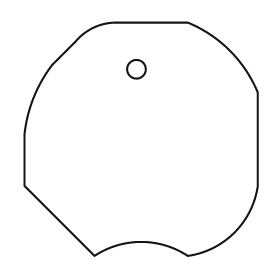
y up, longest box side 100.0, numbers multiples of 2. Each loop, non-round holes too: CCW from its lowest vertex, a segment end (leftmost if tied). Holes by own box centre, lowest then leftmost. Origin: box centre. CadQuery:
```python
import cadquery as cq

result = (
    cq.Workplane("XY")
    .moveTo(-20.0, -50.0)
    .threePointArc((0.0, -44.0), (20.0, -50.0))
    .threePointArc((40.0, -40.0), (50.0, -20.0))
    .lineTo(50.0, 20.0)
    .threePointArc((38.0, 38.0), (20.0, 50.0))
    .lineTo(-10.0, 50.0)
    .threePointArc((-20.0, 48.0), (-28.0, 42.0))
    .lineTo(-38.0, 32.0)
    .threePointArc((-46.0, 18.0), (-50.0, 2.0))
    .lineTo(-50.0, -20.0)
    .close()
    .moveTo(-2.0, 30.0)
    .circle(4.0)
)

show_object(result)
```